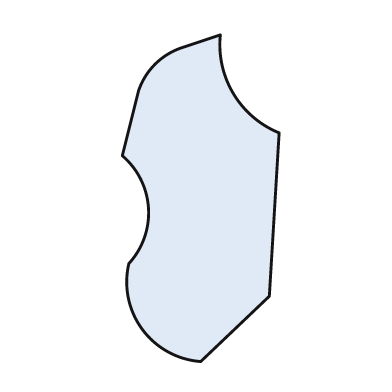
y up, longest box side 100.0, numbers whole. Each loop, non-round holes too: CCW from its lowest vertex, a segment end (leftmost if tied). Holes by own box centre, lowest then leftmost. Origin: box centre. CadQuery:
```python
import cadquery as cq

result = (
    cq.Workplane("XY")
    .moveTo(0.0, -50.0)
    .lineTo(21.0, -30.0)
    .lineTo(24.0, 20.0)
    .threePointArc((10.0, 32.0), (6.0, 50.0))
    .lineTo(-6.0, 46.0)
    .threePointArc((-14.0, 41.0), (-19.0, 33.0))
    .lineTo(-24.0, 13.0)
    .threePointArc((-16.0, -3.0), (-22.0, -20.0))
    .threePointArc((-18.0, -40.0), (0.0, -50.0))
    .close()
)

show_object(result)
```